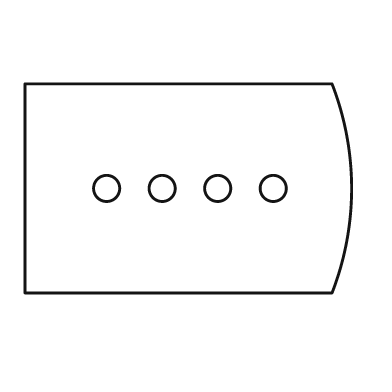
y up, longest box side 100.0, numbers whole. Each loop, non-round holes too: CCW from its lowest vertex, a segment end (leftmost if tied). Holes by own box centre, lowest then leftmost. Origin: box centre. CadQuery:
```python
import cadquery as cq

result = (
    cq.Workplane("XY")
    .moveTo(-50.0, -32.0)
    .lineTo(44.0, -32.0)
    .threePointArc((50.0, 0.0), (44.0, 32.0))
    .lineTo(-50.0, 32.0)
    .close()
    .moveTo(-25.0, 0.0)
    .circle(4.0)
    .moveTo(-8.0, 0.0)
    .circle(4.0)
    .moveTo(9.0, 0.0)
    .circle(4.0)
    .moveTo(26.0, 0.0)
    .circle(4.0)
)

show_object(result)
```